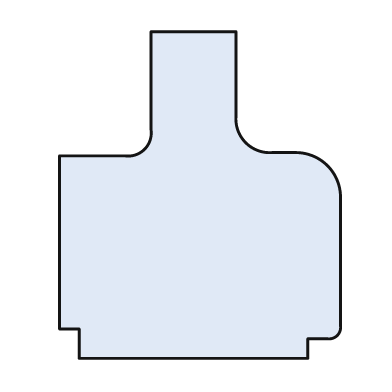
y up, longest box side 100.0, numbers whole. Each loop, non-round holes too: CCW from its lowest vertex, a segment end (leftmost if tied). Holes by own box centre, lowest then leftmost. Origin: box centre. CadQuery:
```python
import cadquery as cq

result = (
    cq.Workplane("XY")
    .moveTo(-37.0, -50.0)
    .lineTo(33.0, -50.0)
    .lineTo(33.0, -44.0)
    .lineTo(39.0, -44.0)
    .threePointArc((42.0, -43.0), (43.0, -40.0))
    .lineTo(43.0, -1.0)
    .threePointArc((39.0, 9.0), (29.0, 13.0))
    .lineTo(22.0, 13.0)
    .threePointArc((14.0, 16.0), (11.0, 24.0))
    .lineTo(11.0, 50.0)
    .lineTo(-15.0, 50.0)
    .lineTo(-15.0, 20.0)
    .threePointArc((-17.0, 14.0), (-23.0, 12.0))
    .lineTo(-43.0, 12.0)
    .lineTo(-43.0, -41.0)
    .lineTo(-37.0, -41.0)
    .close()
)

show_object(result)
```